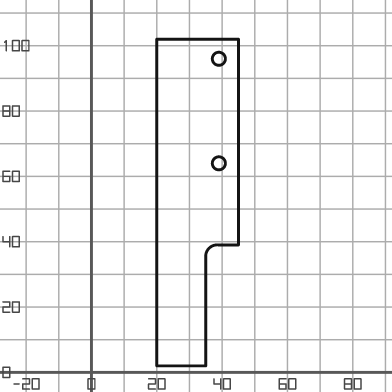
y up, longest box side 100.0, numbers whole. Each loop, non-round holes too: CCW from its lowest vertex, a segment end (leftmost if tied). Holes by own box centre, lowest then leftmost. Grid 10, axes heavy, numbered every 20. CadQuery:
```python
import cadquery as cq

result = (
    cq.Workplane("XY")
    .moveTo(20.0, 2.0)
    .lineTo(35.0, 2.0)
    .lineTo(35.0, 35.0)
    .threePointArc((36.0, 38.0), (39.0, 39.0))
    .lineTo(45.0, 39.0)
    .lineTo(45.0, 102.0)
    .lineTo(20.0, 102.0)
    .close()
    .moveTo(39.0, 64.0)
    .circle(2.0)
    .moveTo(39.0, 96.0)
    .circle(2.0)
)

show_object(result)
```